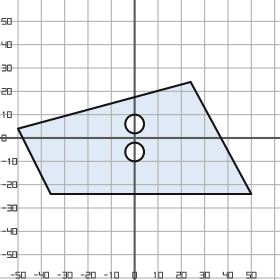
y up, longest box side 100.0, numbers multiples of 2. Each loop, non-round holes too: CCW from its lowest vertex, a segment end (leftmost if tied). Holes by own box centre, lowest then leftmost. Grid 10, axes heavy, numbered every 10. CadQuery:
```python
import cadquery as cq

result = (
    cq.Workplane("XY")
    .moveTo(-36.0, -24.0)
    .lineTo(50.0, -24.0)
    .lineTo(24.0, 24.0)
    .lineTo(-50.0, 4.0)
    .close()
    .moveTo(0.0, -6.0)
    .circle(4.0)
    .moveTo(0.0, 6.0)
    .circle(4.0)
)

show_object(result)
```